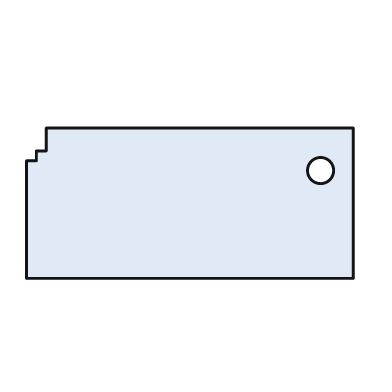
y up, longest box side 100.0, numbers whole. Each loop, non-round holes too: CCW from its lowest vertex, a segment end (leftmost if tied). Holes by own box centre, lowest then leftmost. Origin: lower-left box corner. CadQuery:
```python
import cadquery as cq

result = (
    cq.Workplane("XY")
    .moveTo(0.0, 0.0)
    .lineTo(100.0, 0.0)
    .lineTo(100.0, 46.0)
    .lineTo(6.0, 46.0)
    .lineTo(6.0, 39.0)
    .lineTo(3.0, 39.0)
    .lineTo(3.0, 36.0)
    .lineTo(0.0, 36.0)
    .close()
    .moveTo(90.0, 33.0)
    .circle(4.0)
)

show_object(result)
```